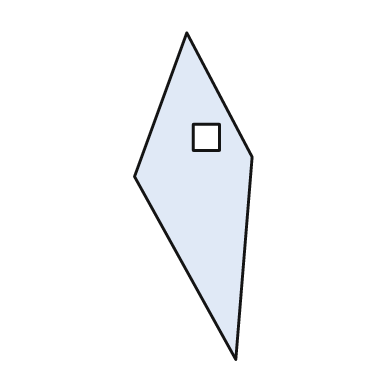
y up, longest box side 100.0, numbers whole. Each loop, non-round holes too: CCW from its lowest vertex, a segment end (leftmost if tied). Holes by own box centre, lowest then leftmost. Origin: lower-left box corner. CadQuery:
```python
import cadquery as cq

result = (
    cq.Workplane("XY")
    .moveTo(31.0, 0.0)
    .lineTo(36.0, 62.0)
    .lineTo(16.0, 100.0)
    .lineTo(0.0, 56.0)
    .close()
    .moveTo(18.0, 64.0)
    .lineTo(26.0, 64.0)
    .lineTo(26.0, 72.0)
    .lineTo(18.0, 72.0)
    .close()
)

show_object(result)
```